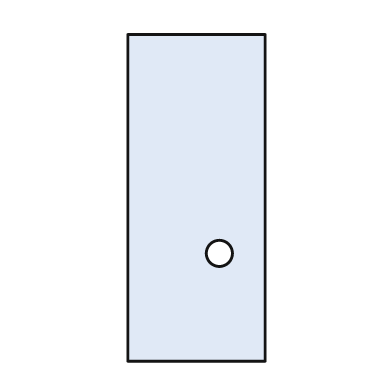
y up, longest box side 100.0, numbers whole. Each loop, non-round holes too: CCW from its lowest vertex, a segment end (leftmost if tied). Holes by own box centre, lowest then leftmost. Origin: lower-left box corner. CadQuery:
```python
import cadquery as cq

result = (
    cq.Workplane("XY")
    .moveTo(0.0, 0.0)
    .lineTo(42.0, 0.0)
    .lineTo(42.0, 100.0)
    .lineTo(0.0, 100.0)
    .close()
    .moveTo(28.0, 33.0)
    .circle(4.0)
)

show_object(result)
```